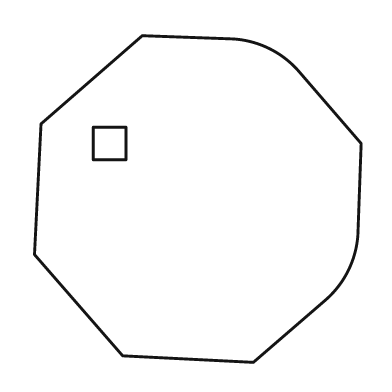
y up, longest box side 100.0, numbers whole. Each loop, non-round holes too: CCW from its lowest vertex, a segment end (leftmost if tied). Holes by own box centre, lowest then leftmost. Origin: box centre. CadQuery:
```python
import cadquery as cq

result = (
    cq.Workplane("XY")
    .moveTo(17.0, -50.0)
    .lineTo(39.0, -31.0)
    .threePointArc((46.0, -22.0), (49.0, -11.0))
    .lineTo(50.0, 17.0)
    .lineTo(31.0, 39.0)
    .threePointArc((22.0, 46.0), (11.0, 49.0))
    .lineTo(-17.0, 50.0)
    .lineTo(-48.0, 23.0)
    .lineTo(-50.0, -17.0)
    .lineTo(-23.0, -48.0)
    .close()
    .moveTo(-32.0, 12.0)
    .lineTo(-22.0, 12.0)
    .lineTo(-22.0, 22.0)
    .lineTo(-32.0, 22.0)
    .close()
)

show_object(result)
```